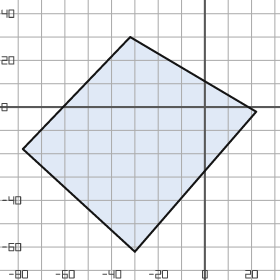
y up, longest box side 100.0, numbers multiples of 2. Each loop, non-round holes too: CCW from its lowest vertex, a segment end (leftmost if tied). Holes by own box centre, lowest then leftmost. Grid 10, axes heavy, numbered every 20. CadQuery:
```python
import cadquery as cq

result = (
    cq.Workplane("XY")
    .moveTo(-30.0, -62.0)
    .lineTo(22.0, -2.0)
    .lineTo(-32.0, 30.0)
    .lineTo(-78.0, -18.0)
    .close()
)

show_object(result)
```